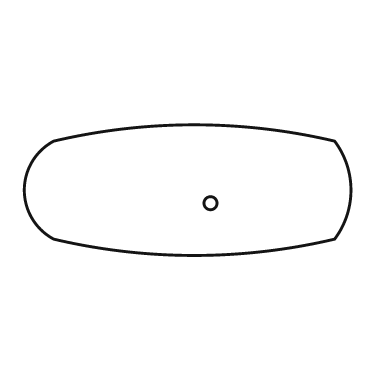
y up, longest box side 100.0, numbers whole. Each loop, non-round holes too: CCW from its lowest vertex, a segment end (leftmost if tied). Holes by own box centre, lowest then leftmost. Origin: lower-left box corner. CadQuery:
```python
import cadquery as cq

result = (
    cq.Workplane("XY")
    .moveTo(9.0, 5.0)
    .threePointArc((52.0, 0.0), (95.0, 5.0))
    .threePointArc((100.0, 20.0), (95.0, 35.0))
    .threePointArc((52.0, 40.0), (9.0, 35.0))
    .threePointArc((0.0, 20.0), (9.0, 5.0))
    .close()
    .moveTo(57.0, 16.0)
    .circle(2.0)
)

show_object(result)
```